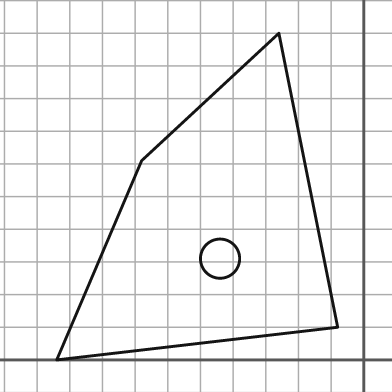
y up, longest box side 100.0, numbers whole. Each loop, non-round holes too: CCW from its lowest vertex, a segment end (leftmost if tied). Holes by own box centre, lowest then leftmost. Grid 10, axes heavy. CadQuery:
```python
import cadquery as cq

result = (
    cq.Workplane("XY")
    .moveTo(-94.0, 0.0)
    .lineTo(-8.0, 10.0)
    .lineTo(-26.0, 100.0)
    .lineTo(-68.0, 61.0)
    .close()
    .moveTo(-44.0, 31.0)
    .circle(6.0)
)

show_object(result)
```